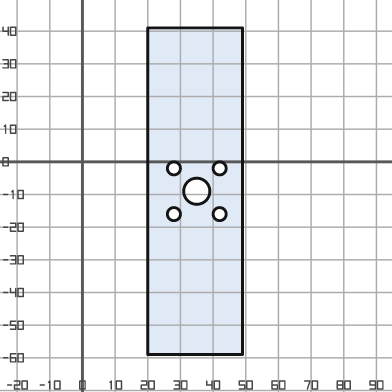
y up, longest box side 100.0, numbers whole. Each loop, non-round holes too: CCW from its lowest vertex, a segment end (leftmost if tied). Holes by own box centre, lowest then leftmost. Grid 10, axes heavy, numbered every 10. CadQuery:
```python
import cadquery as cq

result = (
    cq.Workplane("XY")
    .moveTo(20.0, -59.0)
    .lineTo(49.0, -59.0)
    .lineTo(49.0, 41.0)
    .lineTo(20.0, 41.0)
    .close()
    .moveTo(28.0, -16.0)
    .circle(2.0)
    .moveTo(42.0, -16.0)
    .circle(2.0)
    .moveTo(35.0, -9.0)
    .circle(4.0)
    .moveTo(28.0, -2.0)
    .circle(2.0)
    .moveTo(42.0, -2.0)
    .circle(2.0)
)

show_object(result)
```